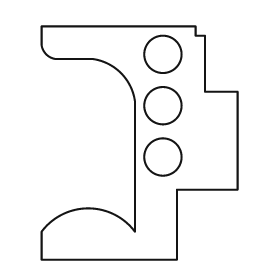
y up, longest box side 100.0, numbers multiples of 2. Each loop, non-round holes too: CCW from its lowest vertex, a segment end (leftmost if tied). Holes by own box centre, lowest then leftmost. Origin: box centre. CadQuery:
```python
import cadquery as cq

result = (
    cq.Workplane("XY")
    .moveTo(-42.0, -50.0)
    .lineTo(16.0, -50.0)
    .lineTo(16.0, -20.0)
    .lineTo(42.0, -20.0)
    .lineTo(42.0, 22.0)
    .lineTo(28.0, 22.0)
    .lineTo(28.0, 46.0)
    .lineTo(24.0, 46.0)
    .lineTo(24.0, 50.0)
    .lineTo(-42.0, 50.0)
    .lineTo(-42.0, 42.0)
    .threePointArc((-40.0, 38.0), (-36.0, 36.0))
    .lineTo(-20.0, 36.0)
    .threePointArc((-8.0, 30.0), (-2.0, 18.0))
    .lineTo(-2.0, -38.0)
    .threePointArc((-22.0, -28.0), (-42.0, -38.0))
    .close()
    .moveTo(10.0, -6.0)
    .circle(8.0)
    .moveTo(10.0, 16.0)
    .circle(8.0)
    .moveTo(10.0, 38.0)
    .circle(8.0)
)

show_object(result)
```